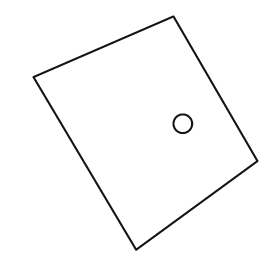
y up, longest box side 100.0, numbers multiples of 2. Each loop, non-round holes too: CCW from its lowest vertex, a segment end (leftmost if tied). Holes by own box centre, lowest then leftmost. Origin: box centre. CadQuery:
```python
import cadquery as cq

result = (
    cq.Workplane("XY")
    .moveTo(-4.0, -50.0)
    .lineTo(48.0, -12.0)
    .lineTo(12.0, 50.0)
    .lineTo(-48.0, 24.0)
    .close()
    .moveTo(16.0, 4.0)
    .circle(4.0)
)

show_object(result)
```